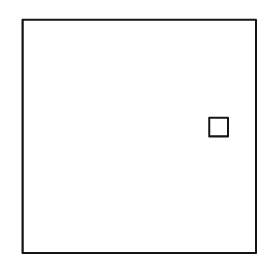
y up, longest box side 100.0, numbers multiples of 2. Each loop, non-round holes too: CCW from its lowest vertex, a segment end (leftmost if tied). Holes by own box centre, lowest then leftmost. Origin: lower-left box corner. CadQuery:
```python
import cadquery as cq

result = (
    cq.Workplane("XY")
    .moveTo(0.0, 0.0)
    .lineTo(100.0, 0.0)
    .lineTo(100.0, 100.0)
    .lineTo(0.0, 100.0)
    .close()
    .moveTo(80.0, 50.0)
    .lineTo(88.0, 50.0)
    .lineTo(88.0, 58.0)
    .lineTo(80.0, 58.0)
    .close()
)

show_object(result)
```